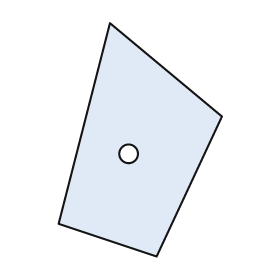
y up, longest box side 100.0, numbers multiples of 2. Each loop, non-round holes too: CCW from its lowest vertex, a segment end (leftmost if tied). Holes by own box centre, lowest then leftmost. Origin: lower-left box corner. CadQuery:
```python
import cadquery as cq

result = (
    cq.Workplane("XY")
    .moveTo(42.0, 0.0)
    .lineTo(70.0, 60.0)
    .lineTo(22.0, 100.0)
    .lineTo(0.0, 14.0)
    .close()
    .moveTo(30.0, 44.0)
    .circle(4.0)
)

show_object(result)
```